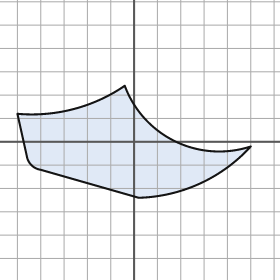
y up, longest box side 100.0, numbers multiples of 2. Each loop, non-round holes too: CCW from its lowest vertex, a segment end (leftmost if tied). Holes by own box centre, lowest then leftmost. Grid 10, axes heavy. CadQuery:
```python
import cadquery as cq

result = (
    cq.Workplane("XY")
    .moveTo(2.0, -24.0)
    .threePointArc((28.0, -18.0), (50.0, -2.0))
    .threePointArc((18.0, 0.0), (-4.0, 24.0))
    .threePointArc((-26.0, 14.0), (-50.0, 12.0))
    .lineTo(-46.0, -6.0)
    .threePointArc((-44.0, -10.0), (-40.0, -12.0))
    .close()
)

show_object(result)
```